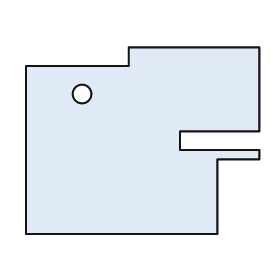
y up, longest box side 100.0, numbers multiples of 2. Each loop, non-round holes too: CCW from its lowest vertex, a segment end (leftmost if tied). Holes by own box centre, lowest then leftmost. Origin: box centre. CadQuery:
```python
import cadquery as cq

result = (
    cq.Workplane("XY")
    .moveTo(-50.0, -40.0)
    .lineTo(32.0, -40.0)
    .lineTo(32.0, -8.0)
    .lineTo(50.0, -8.0)
    .lineTo(50.0, -4.0)
    .lineTo(16.0, -4.0)
    .lineTo(16.0, 4.0)
    .lineTo(50.0, 4.0)
    .lineTo(50.0, 40.0)
    .lineTo(-6.0, 40.0)
    .lineTo(-6.0, 32.0)
    .lineTo(-50.0, 32.0)
    .close()
    .moveTo(-26.0, 20.0)
    .circle(4.0)
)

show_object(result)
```